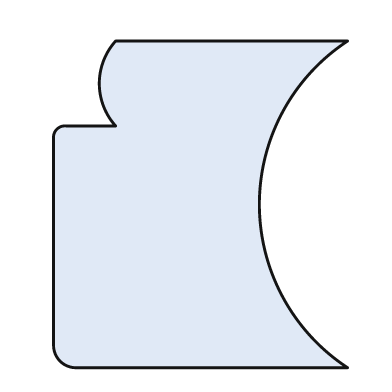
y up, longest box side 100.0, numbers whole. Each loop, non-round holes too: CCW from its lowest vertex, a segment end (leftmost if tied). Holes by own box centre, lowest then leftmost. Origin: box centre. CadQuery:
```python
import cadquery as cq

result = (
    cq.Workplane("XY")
    .moveTo(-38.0, -50.0)
    .lineTo(45.0, -50.0)
    .threePointArc((18.0, 0.0), (45.0, 50.0))
    .lineTo(-26.0, 50.0)
    .threePointArc((-31.0, 37.0), (-26.0, 24.0))
    .lineTo(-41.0, 24.0)
    .threePointArc((-44.0, 23.0), (-45.0, 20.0))
    .lineTo(-45.0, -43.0)
    .threePointArc((-43.0, -48.0), (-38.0, -50.0))
    .close()
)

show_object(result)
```